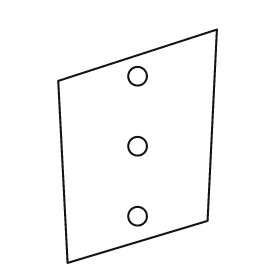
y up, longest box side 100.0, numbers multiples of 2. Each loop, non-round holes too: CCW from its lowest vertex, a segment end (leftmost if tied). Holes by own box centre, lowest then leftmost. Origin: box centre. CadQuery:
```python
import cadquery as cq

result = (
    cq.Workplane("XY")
    .moveTo(-30.0, -50.0)
    .lineTo(30.0, -32.0)
    .lineTo(34.0, 50.0)
    .lineTo(-34.0, 28.0)
    .close()
    .moveTo(0.0, -30.0)
    .circle(4.0)
    .moveTo(0.0, 0.0)
    .circle(4.0)
    .moveTo(0.0, 30.0)
    .circle(4.0)
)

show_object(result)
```